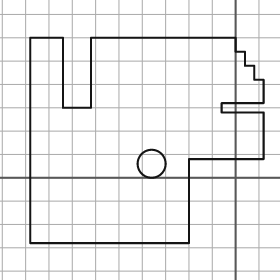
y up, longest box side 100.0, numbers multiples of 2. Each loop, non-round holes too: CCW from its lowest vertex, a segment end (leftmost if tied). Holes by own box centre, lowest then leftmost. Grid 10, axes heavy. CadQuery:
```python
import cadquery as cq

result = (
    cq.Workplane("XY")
    .moveTo(-88.0, -28.0)
    .lineTo(-20.0, -28.0)
    .lineTo(-20.0, 8.0)
    .lineTo(12.0, 8.0)
    .lineTo(12.0, 28.0)
    .lineTo(-6.0, 28.0)
    .lineTo(-6.0, 32.0)
    .lineTo(12.0, 32.0)
    .lineTo(12.0, 42.0)
    .lineTo(8.0, 42.0)
    .lineTo(8.0, 48.0)
    .lineTo(4.0, 48.0)
    .lineTo(4.0, 54.0)
    .lineTo(0.0, 54.0)
    .lineTo(0.0, 60.0)
    .lineTo(-62.0, 60.0)
    .lineTo(-62.0, 30.0)
    .lineTo(-74.0, 30.0)
    .lineTo(-74.0, 60.0)
    .lineTo(-88.0, 60.0)
    .close()
    .moveTo(-36.0, 6.0)
    .circle(6.0)
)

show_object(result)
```